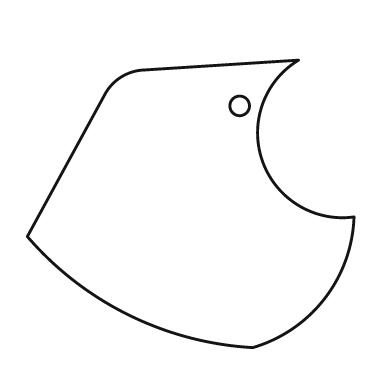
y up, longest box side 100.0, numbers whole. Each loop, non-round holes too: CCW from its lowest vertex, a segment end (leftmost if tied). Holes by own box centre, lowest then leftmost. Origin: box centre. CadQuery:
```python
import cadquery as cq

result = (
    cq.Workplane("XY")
    .moveTo(19.0, -44.0)
    .threePointArc((41.0, -29.0), (50.0, -4.0))
    .threePointArc((22.0, 13.0), (33.0, 44.0))
    .lineTo(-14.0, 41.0)
    .threePointArc((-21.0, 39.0), (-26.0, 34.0))
    .lineTo(-50.0, -10.0)
    .threePointArc((-19.0, -34.0), (19.0, -44.0))
    .close()
    .moveTo(15.0, 30.0)
    .circle(3.0)
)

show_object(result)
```